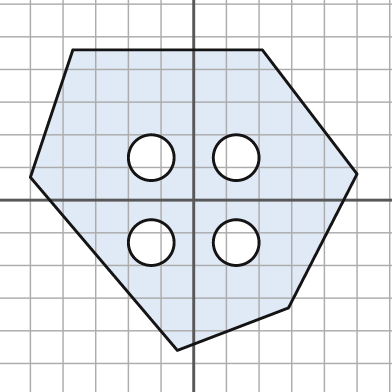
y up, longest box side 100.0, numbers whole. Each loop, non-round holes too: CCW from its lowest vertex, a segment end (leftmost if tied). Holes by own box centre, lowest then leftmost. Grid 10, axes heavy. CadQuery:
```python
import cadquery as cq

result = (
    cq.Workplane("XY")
    .moveTo(-5.0, -46.0)
    .lineTo(29.0, -33.0)
    .lineTo(50.0, 8.0)
    .lineTo(21.0, 46.0)
    .lineTo(-37.0, 46.0)
    .lineTo(-50.0, 7.0)
    .close()
    .moveTo(-13.0, -13.0)
    .circle(7.0)
    .moveTo(13.0, -13.0)
    .circle(7.0)
    .moveTo(-13.0, 13.0)
    .circle(7.0)
    .moveTo(13.0, 13.0)
    .circle(7.0)
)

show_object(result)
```